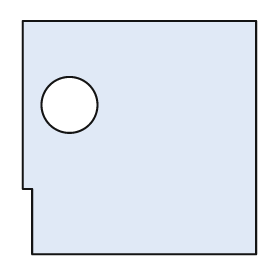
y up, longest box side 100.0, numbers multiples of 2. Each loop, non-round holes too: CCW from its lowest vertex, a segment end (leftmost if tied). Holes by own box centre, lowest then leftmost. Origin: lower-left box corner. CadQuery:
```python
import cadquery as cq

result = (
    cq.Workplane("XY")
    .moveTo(4.0, 0.0)
    .lineTo(100.0, 0.0)
    .lineTo(100.0, 100.0)
    .lineTo(0.0, 100.0)
    .lineTo(0.0, 28.0)
    .lineTo(4.0, 28.0)
    .close()
    .moveTo(20.0, 64.0)
    .circle(12.0)
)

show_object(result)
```